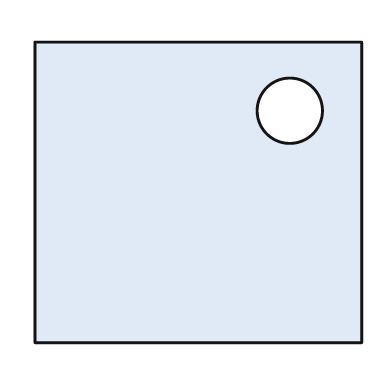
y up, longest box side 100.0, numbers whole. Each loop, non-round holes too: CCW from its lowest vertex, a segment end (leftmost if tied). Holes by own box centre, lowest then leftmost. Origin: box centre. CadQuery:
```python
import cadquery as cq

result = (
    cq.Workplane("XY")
    .moveTo(-50.0, -46.0)
    .lineTo(50.0, -46.0)
    .lineTo(50.0, 46.0)
    .lineTo(-50.0, 46.0)
    .close()
    .moveTo(28.0, 25.0)
    .circle(10.0)
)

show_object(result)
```